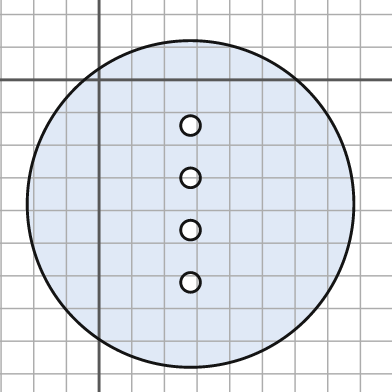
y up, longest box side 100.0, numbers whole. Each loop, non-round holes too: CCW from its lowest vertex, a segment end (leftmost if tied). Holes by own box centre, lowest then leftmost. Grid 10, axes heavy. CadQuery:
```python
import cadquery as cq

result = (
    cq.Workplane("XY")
    .moveTo(28.0, -38.0)
    .circle(50.0)
    .moveTo(28.0, -62.0)
    .circle(3.0)
    .moveTo(28.0, -46.0)
    .circle(3.0)
    .moveTo(28.0, -30.0)
    .circle(3.0)
    .moveTo(28.0, -14.0)
    .circle(3.0)
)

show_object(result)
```